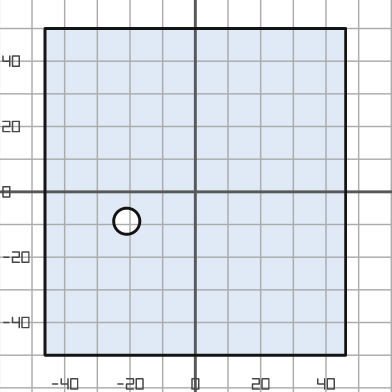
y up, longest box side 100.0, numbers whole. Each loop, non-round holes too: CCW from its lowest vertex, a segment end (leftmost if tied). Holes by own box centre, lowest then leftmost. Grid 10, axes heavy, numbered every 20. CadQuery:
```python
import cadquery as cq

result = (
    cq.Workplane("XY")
    .moveTo(-46.0, -50.0)
    .lineTo(46.0, -50.0)
    .lineTo(46.0, 50.0)
    .lineTo(-46.0, 50.0)
    .close()
    .moveTo(-21.0, -9.0)
    .circle(4.0)
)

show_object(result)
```